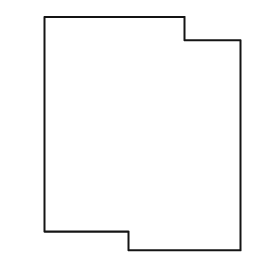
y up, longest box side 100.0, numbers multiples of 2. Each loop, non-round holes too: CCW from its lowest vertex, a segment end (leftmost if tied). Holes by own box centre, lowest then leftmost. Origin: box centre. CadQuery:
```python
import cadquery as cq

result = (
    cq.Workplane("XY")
    .moveTo(-6.0, -50.0)
    .lineTo(42.0, -50.0)
    .lineTo(42.0, 40.0)
    .lineTo(18.0, 40.0)
    .lineTo(18.0, 50.0)
    .lineTo(-42.0, 50.0)
    .lineTo(-42.0, -42.0)
    .lineTo(-6.0, -42.0)
    .close()
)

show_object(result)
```